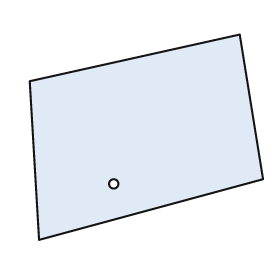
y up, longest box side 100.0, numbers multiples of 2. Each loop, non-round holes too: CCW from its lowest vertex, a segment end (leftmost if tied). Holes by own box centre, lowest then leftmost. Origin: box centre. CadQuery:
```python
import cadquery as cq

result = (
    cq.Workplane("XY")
    .moveTo(-46.0, -44.0)
    .lineTo(50.0, -18.0)
    .lineTo(40.0, 44.0)
    .lineTo(-50.0, 24.0)
    .close()
    .moveTo(-14.0, -20.0)
    .circle(2.0)
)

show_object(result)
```